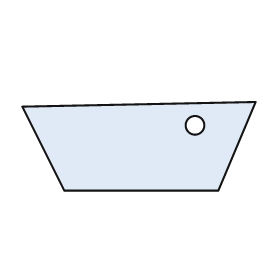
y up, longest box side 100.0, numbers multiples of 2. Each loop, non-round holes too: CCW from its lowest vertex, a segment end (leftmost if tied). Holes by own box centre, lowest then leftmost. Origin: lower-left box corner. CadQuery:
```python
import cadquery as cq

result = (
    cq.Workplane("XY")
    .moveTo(18.0, 0.0)
    .lineTo(84.0, 0.0)
    .lineTo(100.0, 38.0)
    .lineTo(0.0, 36.0)
    .close()
    .moveTo(74.0, 28.0)
    .circle(4.0)
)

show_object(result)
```